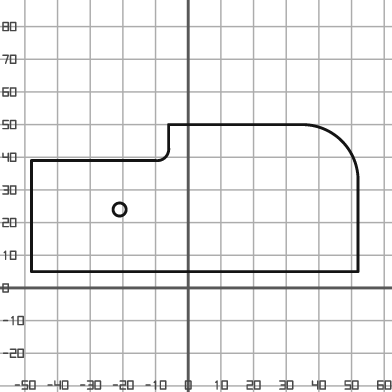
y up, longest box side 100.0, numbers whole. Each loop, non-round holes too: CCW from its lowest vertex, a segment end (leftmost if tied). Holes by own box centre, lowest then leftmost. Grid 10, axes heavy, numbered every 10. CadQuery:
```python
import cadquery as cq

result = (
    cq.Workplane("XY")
    .moveTo(-48.0, 5.0)
    .lineTo(52.0, 5.0)
    .lineTo(52.0, 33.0)
    .threePointArc((47.0, 45.0), (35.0, 50.0))
    .lineTo(-6.0, 50.0)
    .lineTo(-6.0, 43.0)
    .threePointArc((-7.0, 40.0), (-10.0, 39.0))
    .lineTo(-48.0, 39.0)
    .close()
    .moveTo(-21.0, 24.0)
    .circle(2.0)
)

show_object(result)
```